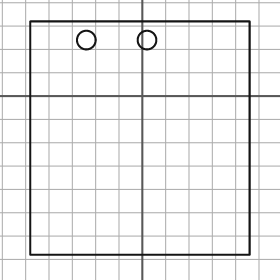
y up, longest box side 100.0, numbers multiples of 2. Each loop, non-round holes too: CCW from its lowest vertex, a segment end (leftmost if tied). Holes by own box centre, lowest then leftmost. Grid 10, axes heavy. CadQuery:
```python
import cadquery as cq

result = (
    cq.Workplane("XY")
    .moveTo(-48.0, -68.0)
    .lineTo(46.0, -68.0)
    .lineTo(46.0, 32.0)
    .lineTo(-48.0, 32.0)
    .close()
    .moveTo(-24.0, 24.0)
    .circle(4.0)
    .moveTo(2.0, 24.0)
    .circle(4.0)
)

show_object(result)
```